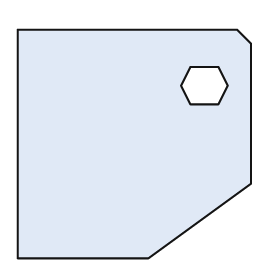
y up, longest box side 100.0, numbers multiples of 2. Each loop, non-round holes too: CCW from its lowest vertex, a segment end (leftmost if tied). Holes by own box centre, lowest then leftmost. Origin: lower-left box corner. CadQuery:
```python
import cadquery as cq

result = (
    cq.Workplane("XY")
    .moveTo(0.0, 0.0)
    .lineTo(56.0, 0.0)
    .lineTo(100.0, 32.0)
    .lineTo(100.0, 92.0)
    .lineTo(94.0, 98.0)
    .lineTo(0.0, 98.0)
    .close()
    .moveTo(74.0, 66.0)
    .lineTo(86.0, 66.0)
    .lineTo(90.0, 74.0)
    .lineTo(86.0, 82.0)
    .lineTo(74.0, 82.0)
    .lineTo(70.0, 74.0)
    .close()
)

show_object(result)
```